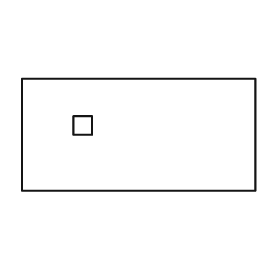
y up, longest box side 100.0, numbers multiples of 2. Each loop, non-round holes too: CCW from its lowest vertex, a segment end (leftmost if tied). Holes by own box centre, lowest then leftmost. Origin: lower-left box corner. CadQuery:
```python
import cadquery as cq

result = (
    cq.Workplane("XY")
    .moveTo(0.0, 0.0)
    .lineTo(100.0, 0.0)
    .lineTo(100.0, 48.0)
    .lineTo(0.0, 48.0)
    .close()
    .moveTo(22.0, 24.0)
    .lineTo(30.0, 24.0)
    .lineTo(30.0, 32.0)
    .lineTo(22.0, 32.0)
    .close()
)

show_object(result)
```